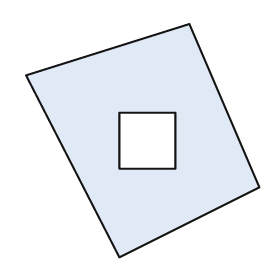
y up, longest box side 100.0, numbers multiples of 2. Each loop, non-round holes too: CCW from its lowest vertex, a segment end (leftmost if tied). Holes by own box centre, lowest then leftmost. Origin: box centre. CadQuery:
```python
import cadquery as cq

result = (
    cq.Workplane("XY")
    .moveTo(-10.0, -50.0)
    .lineTo(50.0, -20.0)
    .lineTo(20.0, 50.0)
    .lineTo(-50.0, 28.0)
    .close()
    .moveTo(-10.0, -12.0)
    .lineTo(14.0, -12.0)
    .lineTo(14.0, 12.0)
    .lineTo(-10.0, 12.0)
    .close()
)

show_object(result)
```